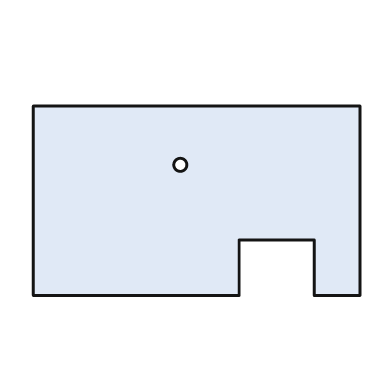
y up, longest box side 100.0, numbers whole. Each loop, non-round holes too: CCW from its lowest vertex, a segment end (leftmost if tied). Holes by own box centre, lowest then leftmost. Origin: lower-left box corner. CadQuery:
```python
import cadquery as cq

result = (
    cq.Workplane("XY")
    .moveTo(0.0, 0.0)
    .lineTo(63.0, 0.0)
    .lineTo(63.0, 17.0)
    .lineTo(86.0, 17.0)
    .lineTo(86.0, 0.0)
    .lineTo(100.0, 0.0)
    .lineTo(100.0, 58.0)
    .lineTo(0.0, 58.0)
    .close()
    .moveTo(45.0, 40.0)
    .circle(2.0)
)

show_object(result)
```